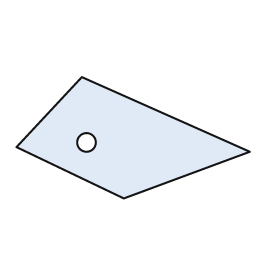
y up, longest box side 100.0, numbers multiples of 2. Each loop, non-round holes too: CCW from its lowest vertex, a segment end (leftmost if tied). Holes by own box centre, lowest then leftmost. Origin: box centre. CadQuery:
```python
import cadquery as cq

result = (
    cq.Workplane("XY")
    .moveTo(-4.0, -26.0)
    .lineTo(50.0, -6.0)
    .lineTo(-22.0, 26.0)
    .lineTo(-50.0, -4.0)
    .close()
    .moveTo(-20.0, -2.0)
    .circle(4.0)
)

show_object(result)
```